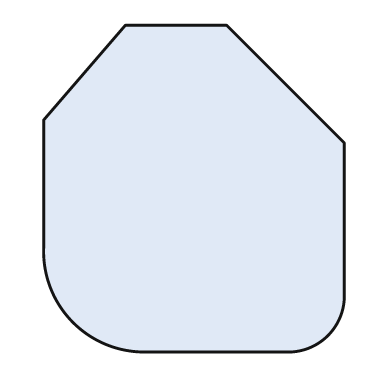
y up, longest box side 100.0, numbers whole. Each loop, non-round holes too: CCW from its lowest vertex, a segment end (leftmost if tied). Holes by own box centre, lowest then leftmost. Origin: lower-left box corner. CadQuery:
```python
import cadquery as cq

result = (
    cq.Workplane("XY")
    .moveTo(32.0, 0.0)
    .lineTo(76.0, 0.0)
    .threePointArc((87.0, 5.0), (92.0, 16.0))
    .lineTo(92.0, 64.0)
    .lineTo(56.0, 100.0)
    .lineTo(25.0, 100.0)
    .lineTo(0.0, 71.0)
    .lineTo(0.0, 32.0)
    .threePointArc((9.0, 9.0), (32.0, 0.0))
    .close()
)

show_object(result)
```